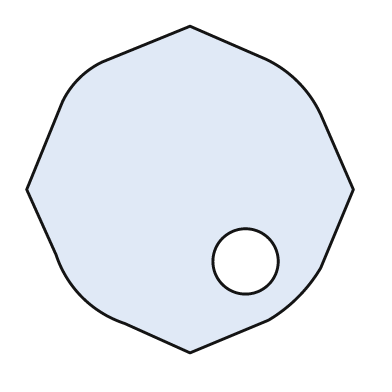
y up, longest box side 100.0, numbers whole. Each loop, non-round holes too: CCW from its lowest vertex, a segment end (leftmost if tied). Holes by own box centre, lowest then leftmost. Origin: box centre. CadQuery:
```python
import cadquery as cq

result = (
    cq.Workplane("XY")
    .moveTo(0.0, -50.0)
    .lineTo(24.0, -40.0)
    .threePointArc((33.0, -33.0), (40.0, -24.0))
    .lineTo(50.0, 0.0)
    .lineTo(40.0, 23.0)
    .threePointArc((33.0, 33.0), (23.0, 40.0))
    .lineTo(0.0, 50.0)
    .lineTo(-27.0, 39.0)
    .threePointArc((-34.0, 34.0), (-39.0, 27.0))
    .lineTo(-50.0, 0.0)
    .lineTo(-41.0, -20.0)
    .threePointArc((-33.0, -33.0), (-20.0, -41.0))
    .close()
    .moveTo(17.0, -22.0)
    .circle(10.0)
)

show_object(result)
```